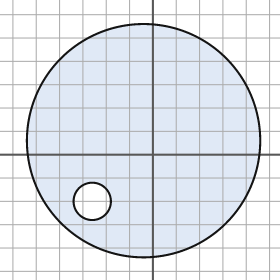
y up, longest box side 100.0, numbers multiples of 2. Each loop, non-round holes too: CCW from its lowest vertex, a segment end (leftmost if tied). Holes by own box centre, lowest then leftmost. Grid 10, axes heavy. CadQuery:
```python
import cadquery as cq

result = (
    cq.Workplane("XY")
    .moveTo(-4.0, 6.0)
    .circle(50.0)
    .moveTo(-26.0, -20.0)
    .circle(8.0)
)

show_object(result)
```